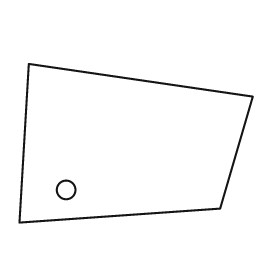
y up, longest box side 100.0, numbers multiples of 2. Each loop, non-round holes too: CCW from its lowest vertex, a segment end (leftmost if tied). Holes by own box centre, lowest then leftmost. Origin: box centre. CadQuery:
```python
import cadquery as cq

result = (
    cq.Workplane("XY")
    .moveTo(-50.0, -34.0)
    .lineTo(36.0, -28.0)
    .lineTo(50.0, 20.0)
    .lineTo(-46.0, 34.0)
    .close()
    .moveTo(-30.0, -20.0)
    .circle(4.0)
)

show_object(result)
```